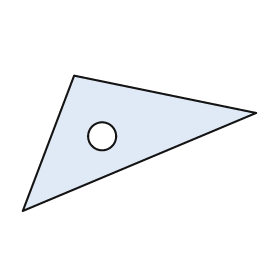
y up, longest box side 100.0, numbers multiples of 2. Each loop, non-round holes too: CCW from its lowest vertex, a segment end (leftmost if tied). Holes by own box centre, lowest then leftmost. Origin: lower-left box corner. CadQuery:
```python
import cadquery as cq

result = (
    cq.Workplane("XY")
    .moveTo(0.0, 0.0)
    .lineTo(100.0, 42.0)
    .lineTo(22.0, 58.0)
    .close()
    .moveTo(34.0, 32.0)
    .circle(6.0)
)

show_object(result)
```